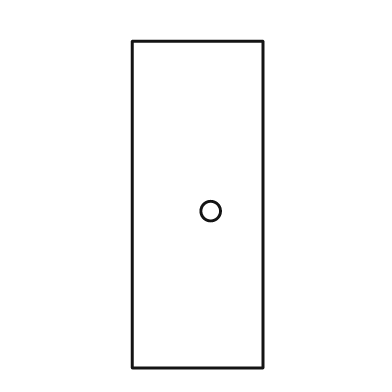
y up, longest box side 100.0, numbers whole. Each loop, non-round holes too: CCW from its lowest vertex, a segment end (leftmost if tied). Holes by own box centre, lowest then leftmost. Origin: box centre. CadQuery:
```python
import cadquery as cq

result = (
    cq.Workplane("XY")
    .moveTo(-20.0, -50.0)
    .lineTo(20.0, -50.0)
    .lineTo(20.0, 50.0)
    .lineTo(-20.0, 50.0)
    .close()
    .moveTo(4.0, -2.0)
    .circle(3.0)
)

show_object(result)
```